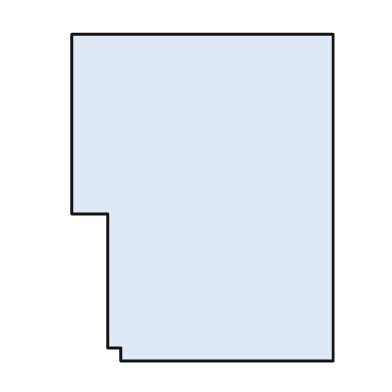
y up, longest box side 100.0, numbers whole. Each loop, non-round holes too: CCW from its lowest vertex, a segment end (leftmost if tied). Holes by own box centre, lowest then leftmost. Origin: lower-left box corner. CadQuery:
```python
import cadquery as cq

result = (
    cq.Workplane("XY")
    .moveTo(15.0, 0.0)
    .lineTo(80.0, 0.0)
    .lineTo(80.0, 100.0)
    .lineTo(0.0, 100.0)
    .lineTo(0.0, 45.0)
    .lineTo(11.0, 45.0)
    .lineTo(11.0, 4.0)
    .lineTo(15.0, 4.0)
    .close()
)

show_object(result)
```